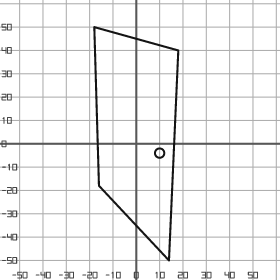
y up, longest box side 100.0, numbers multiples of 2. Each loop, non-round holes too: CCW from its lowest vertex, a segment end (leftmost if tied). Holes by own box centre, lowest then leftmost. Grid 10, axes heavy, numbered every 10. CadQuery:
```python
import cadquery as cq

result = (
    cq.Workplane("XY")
    .moveTo(14.0, -50.0)
    .lineTo(18.0, 40.0)
    .lineTo(-18.0, 50.0)
    .lineTo(-16.0, -18.0)
    .close()
    .moveTo(10.0, -4.0)
    .circle(2.0)
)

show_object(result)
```